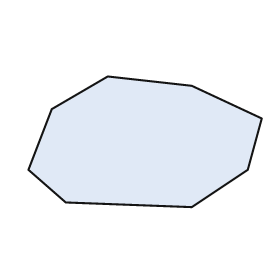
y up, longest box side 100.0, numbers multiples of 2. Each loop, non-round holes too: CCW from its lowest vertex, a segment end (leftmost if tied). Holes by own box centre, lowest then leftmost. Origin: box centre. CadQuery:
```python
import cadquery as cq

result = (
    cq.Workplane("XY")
    .moveTo(20.0, -28.0)
    .lineTo(44.0, -12.0)
    .lineTo(50.0, 10.0)
    .lineTo(20.0, 24.0)
    .lineTo(-16.0, 28.0)
    .lineTo(-40.0, 14.0)
    .lineTo(-50.0, -12.0)
    .lineTo(-34.0, -26.0)
    .close()
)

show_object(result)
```